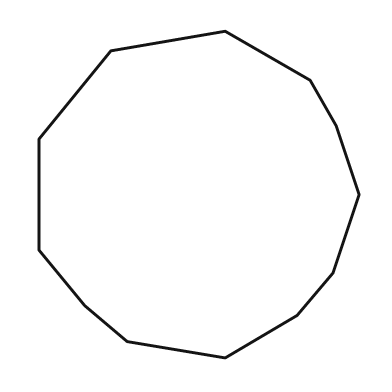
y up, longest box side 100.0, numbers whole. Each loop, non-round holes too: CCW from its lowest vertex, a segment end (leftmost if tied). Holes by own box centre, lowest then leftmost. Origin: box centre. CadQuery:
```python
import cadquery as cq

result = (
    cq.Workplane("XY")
    .moveTo(8.0, -50.0)
    .lineTo(30.0, -37.0)
    .lineTo(41.0, -24.0)
    .lineTo(49.0, 0.0)
    .lineTo(42.0, 21.0)
    .lineTo(34.0, 35.0)
    .lineTo(8.0, 50.0)
    .lineTo(-27.0, 44.0)
    .lineTo(-49.0, 17.0)
    .lineTo(-49.0, -17.0)
    .lineTo(-35.0, -34.0)
    .lineTo(-22.0, -45.0)
    .close()
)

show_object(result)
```